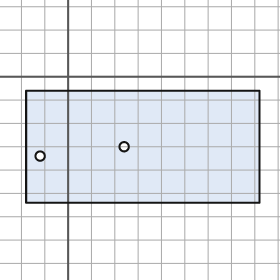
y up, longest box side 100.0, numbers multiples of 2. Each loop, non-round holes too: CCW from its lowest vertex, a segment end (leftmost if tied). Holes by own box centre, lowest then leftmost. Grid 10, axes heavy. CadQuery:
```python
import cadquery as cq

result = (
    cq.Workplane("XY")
    .moveTo(-18.0, -54.0)
    .lineTo(82.0, -54.0)
    .lineTo(82.0, -6.0)
    .lineTo(-18.0, -6.0)
    .close()
    .moveTo(-12.0, -34.0)
    .circle(2.0)
    .moveTo(24.0, -30.0)
    .circle(2.0)
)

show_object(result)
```